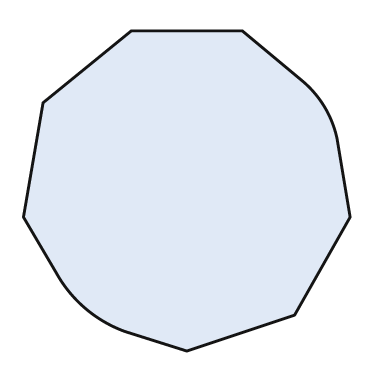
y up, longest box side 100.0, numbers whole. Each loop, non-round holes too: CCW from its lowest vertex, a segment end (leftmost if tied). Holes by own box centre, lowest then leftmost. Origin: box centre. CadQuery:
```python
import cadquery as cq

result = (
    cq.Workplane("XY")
    .moveTo(0.0, -49.0)
    .lineTo(33.0, -38.0)
    .lineTo(50.0, -8.0)
    .lineTo(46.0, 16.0)
    .threePointArc((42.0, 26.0), (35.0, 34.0))
    .lineTo(17.0, 49.0)
    .lineTo(-17.0, 49.0)
    .lineTo(-44.0, 27.0)
    .lineTo(-50.0, -8.0)
    .lineTo(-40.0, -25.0)
    .threePointArc((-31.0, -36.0), (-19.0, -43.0))
    .close()
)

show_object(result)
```